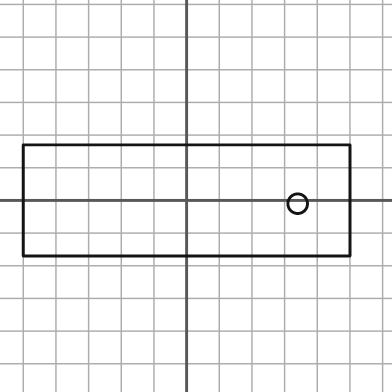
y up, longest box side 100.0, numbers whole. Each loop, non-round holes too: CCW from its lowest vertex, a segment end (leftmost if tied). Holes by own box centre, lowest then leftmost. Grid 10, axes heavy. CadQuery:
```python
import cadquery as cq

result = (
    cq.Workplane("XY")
    .moveTo(-50.0, -17.0)
    .lineTo(50.0, -17.0)
    .lineTo(50.0, 17.0)
    .lineTo(-50.0, 17.0)
    .close()
    .moveTo(34.0, -1.0)
    .circle(3.0)
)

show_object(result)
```